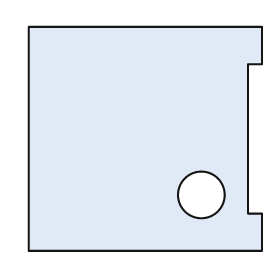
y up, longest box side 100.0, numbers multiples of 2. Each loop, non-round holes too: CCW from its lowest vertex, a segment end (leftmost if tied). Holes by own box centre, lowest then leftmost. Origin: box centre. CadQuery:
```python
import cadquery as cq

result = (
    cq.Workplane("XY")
    .moveTo(-50.0, -48.0)
    .lineTo(50.0, -48.0)
    .lineTo(50.0, -32.0)
    .lineTo(44.0, -32.0)
    .lineTo(44.0, 32.0)
    .lineTo(50.0, 32.0)
    .lineTo(50.0, 48.0)
    .lineTo(-50.0, 48.0)
    .close()
    .moveTo(24.0, -24.0)
    .circle(10.0)
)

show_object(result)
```